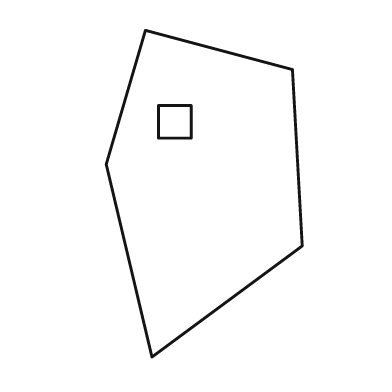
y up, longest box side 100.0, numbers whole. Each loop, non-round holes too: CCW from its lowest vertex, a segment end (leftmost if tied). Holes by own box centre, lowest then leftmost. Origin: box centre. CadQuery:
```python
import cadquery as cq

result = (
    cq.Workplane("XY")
    .moveTo(-16.0, -50.0)
    .lineTo(30.0, -16.0)
    .lineTo(27.0, 38.0)
    .lineTo(-18.0, 50.0)
    .lineTo(-30.0, 9.0)
    .close()
    .moveTo(-14.0, 17.0)
    .lineTo(-4.0, 17.0)
    .lineTo(-4.0, 27.0)
    .lineTo(-14.0, 27.0)
    .close()
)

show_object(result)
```